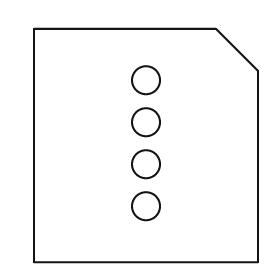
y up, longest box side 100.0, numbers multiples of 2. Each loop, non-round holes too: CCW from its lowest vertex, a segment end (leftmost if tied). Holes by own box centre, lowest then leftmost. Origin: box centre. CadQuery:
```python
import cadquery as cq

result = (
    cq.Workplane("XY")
    .moveTo(-48.0, -50.0)
    .lineTo(48.0, -50.0)
    .lineTo(48.0, 32.0)
    .lineTo(30.0, 50.0)
    .lineTo(-48.0, 50.0)
    .close()
    .moveTo(0.0, -26.0)
    .circle(6.0)
    .moveTo(0.0, -8.0)
    .circle(6.0)
    .moveTo(0.0, 10.0)
    .circle(6.0)
    .moveTo(0.0, 28.0)
    .circle(6.0)
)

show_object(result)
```